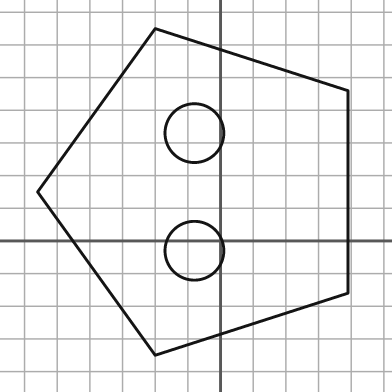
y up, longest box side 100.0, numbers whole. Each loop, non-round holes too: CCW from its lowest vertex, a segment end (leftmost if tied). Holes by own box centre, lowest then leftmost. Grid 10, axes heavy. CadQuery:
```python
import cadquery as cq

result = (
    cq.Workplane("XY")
    .moveTo(-20.0, -35.0)
    .lineTo(39.0, -16.0)
    .lineTo(39.0, 46.0)
    .lineTo(-20.0, 65.0)
    .lineTo(-56.0, 15.0)
    .close()
    .moveTo(-8.0, -3.0)
    .circle(9.0)
    .moveTo(-8.0, 33.0)
    .circle(9.0)
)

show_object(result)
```